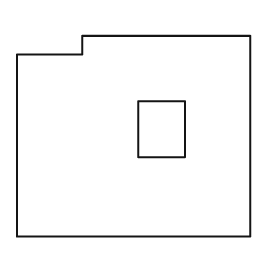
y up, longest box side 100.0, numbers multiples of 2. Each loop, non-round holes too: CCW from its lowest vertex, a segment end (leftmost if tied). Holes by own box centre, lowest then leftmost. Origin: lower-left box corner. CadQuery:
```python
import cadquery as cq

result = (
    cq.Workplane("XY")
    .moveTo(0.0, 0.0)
    .lineTo(100.0, 0.0)
    .lineTo(100.0, 86.0)
    .lineTo(28.0, 86.0)
    .lineTo(28.0, 78.0)
    .lineTo(0.0, 78.0)
    .close()
    .moveTo(52.0, 34.0)
    .lineTo(72.0, 34.0)
    .lineTo(72.0, 58.0)
    .lineTo(52.0, 58.0)
    .close()
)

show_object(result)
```